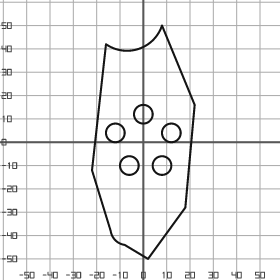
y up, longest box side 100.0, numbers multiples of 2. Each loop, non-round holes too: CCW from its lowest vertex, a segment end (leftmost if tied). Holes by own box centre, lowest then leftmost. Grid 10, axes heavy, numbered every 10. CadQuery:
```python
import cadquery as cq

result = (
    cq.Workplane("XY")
    .moveTo(2.0, -50.0)
    .lineTo(18.0, -28.0)
    .lineTo(22.0, 16.0)
    .lineTo(8.0, 50.0)
    .threePointArc((-2.0, 40.0), (-16.0, 42.0))
    .lineTo(-22.0, -12.0)
    .lineTo(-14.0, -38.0)
    .threePointArc((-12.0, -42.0), (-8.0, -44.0))
    .close()
    .moveTo(-6.0, -10.0)
    .circle(4.0)
    .moveTo(8.0, -10.0)
    .circle(4.0)
    .moveTo(-12.0, 4.0)
    .circle(4.0)
    .moveTo(12.0, 4.0)
    .circle(4.0)
    .moveTo(0.0, 12.0)
    .circle(4.0)
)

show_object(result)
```